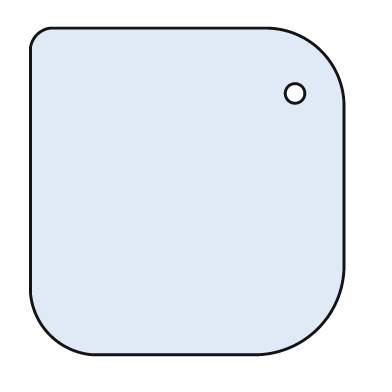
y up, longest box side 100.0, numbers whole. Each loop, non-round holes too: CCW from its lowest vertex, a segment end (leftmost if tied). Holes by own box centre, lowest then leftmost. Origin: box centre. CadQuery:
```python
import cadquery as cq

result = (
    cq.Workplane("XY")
    .moveTo(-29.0, -50.0)
    .lineTo(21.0, -50.0)
    .threePointArc((40.0, -42.0), (48.0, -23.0))
    .lineTo(48.0, 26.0)
    .threePointArc((41.0, 43.0), (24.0, 50.0))
    .lineTo(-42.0, 50.0)
    .threePointArc((-46.0, 48.0), (-48.0, 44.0))
    .lineTo(-48.0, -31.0)
    .threePointArc((-42.0, -44.0), (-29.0, -50.0))
    .close()
    .moveTo(33.0, 30.0)
    .circle(3.0)
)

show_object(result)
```